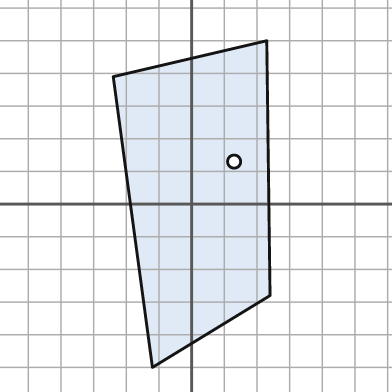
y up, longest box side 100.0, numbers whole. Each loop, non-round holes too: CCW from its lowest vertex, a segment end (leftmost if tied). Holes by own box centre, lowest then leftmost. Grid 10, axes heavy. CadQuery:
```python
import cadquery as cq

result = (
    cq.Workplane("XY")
    .moveTo(-12.0, -50.0)
    .lineTo(24.0, -28.0)
    .lineTo(23.0, 50.0)
    .lineTo(-24.0, 39.0)
    .close()
    .moveTo(13.0, 13.0)
    .circle(2.0)
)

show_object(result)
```